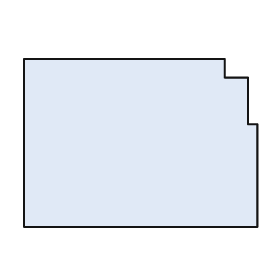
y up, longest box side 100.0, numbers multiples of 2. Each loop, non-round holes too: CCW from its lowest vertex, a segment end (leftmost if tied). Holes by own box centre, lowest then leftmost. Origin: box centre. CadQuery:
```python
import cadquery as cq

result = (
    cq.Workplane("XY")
    .moveTo(-50.0, -36.0)
    .lineTo(50.0, -36.0)
    .lineTo(50.0, 8.0)
    .lineTo(46.0, 8.0)
    .lineTo(46.0, 28.0)
    .lineTo(36.0, 28.0)
    .lineTo(36.0, 36.0)
    .lineTo(-50.0, 36.0)
    .close()
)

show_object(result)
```